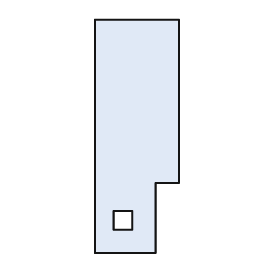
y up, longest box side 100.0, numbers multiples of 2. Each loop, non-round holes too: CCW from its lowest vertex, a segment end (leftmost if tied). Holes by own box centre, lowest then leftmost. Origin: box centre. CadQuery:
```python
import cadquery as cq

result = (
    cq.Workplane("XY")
    .moveTo(-18.0, -50.0)
    .lineTo(8.0, -50.0)
    .lineTo(8.0, -20.0)
    .lineTo(18.0, -20.0)
    .lineTo(18.0, 50.0)
    .lineTo(-18.0, 50.0)
    .close()
    .moveTo(-10.0, -40.0)
    .lineTo(-2.0, -40.0)
    .lineTo(-2.0, -32.0)
    .lineTo(-10.0, -32.0)
    .close()
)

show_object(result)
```